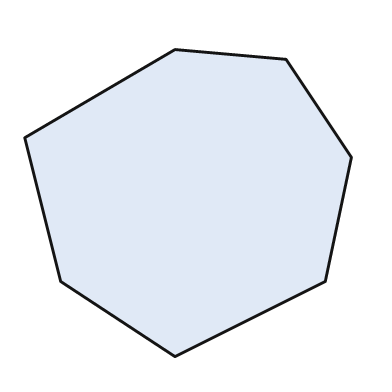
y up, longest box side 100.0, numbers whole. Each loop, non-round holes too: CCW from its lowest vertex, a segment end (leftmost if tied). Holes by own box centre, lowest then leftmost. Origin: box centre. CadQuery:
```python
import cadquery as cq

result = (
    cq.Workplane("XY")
    .moveTo(-4.0, -47.0)
    .lineTo(42.0, -24.0)
    .lineTo(50.0, 14.0)
    .lineTo(30.0, 44.0)
    .lineTo(-4.0, 47.0)
    .lineTo(-50.0, 20.0)
    .lineTo(-39.0, -24.0)
    .close()
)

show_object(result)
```